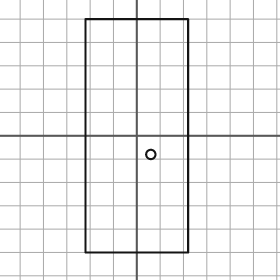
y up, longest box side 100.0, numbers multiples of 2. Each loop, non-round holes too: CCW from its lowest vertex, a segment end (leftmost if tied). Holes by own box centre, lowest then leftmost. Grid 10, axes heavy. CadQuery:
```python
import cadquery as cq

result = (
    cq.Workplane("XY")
    .moveTo(-22.0, -50.0)
    .lineTo(22.0, -50.0)
    .lineTo(22.0, 50.0)
    .lineTo(-22.0, 50.0)
    .close()
    .moveTo(6.0, -8.0)
    .circle(2.0)
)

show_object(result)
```